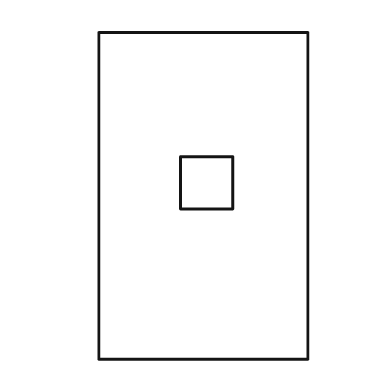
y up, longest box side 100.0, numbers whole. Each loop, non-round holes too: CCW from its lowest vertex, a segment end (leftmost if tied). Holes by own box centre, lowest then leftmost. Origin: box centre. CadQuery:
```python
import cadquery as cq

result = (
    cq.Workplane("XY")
    .moveTo(-32.0, -50.0)
    .lineTo(32.0, -50.0)
    .lineTo(32.0, 50.0)
    .lineTo(-32.0, 50.0)
    .close()
    .moveTo(-7.0, -4.0)
    .lineTo(9.0, -4.0)
    .lineTo(9.0, 12.0)
    .lineTo(-7.0, 12.0)
    .close()
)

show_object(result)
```